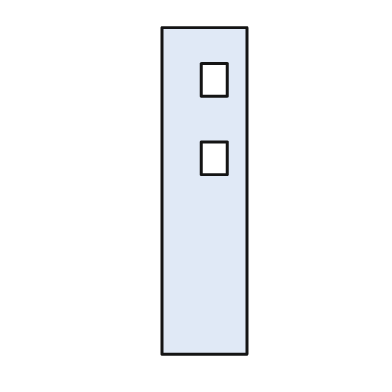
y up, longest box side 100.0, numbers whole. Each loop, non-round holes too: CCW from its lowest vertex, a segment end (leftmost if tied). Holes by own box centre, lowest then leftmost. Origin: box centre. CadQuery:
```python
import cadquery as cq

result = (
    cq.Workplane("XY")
    .moveTo(-13.0, -50.0)
    .lineTo(13.0, -50.0)
    .lineTo(13.0, 50.0)
    .lineTo(-13.0, 50.0)
    .close()
    .moveTo(-1.0, 5.0)
    .lineTo(7.0, 5.0)
    .lineTo(7.0, 15.0)
    .lineTo(-1.0, 15.0)
    .close()
    .moveTo(-1.0, 29.0)
    .lineTo(7.0, 29.0)
    .lineTo(7.0, 39.0)
    .lineTo(-1.0, 39.0)
    .close()
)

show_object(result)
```